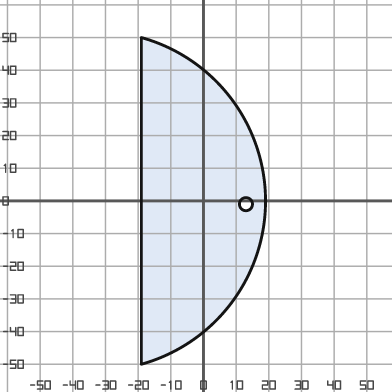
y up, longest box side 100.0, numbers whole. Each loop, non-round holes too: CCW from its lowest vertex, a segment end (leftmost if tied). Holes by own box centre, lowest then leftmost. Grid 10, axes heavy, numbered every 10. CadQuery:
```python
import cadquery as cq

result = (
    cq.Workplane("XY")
    .moveTo(-19.0, -50.0)
    .threePointArc((19.0, 0.0), (-19.0, 50.0))
    .close()
    .moveTo(13.0, -1.0)
    .circle(2.0)
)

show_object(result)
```